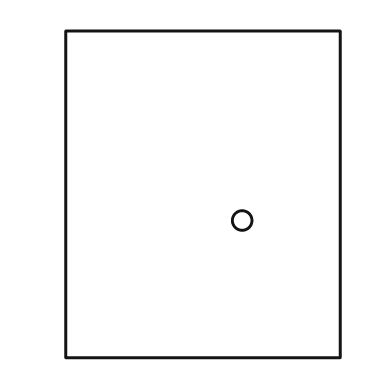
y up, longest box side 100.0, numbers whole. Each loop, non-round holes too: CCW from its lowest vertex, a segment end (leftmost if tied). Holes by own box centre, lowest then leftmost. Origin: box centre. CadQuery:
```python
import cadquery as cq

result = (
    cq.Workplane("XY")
    .moveTo(-42.0, -50.0)
    .lineTo(42.0, -50.0)
    .lineTo(42.0, 50.0)
    .lineTo(-42.0, 50.0)
    .close()
    .moveTo(12.0, -8.0)
    .circle(3.0)
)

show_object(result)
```